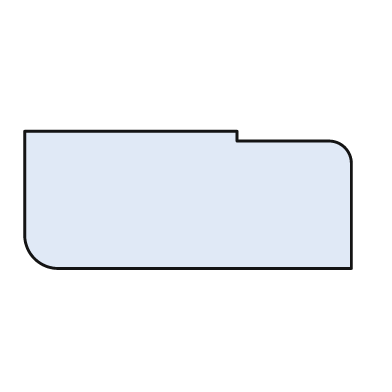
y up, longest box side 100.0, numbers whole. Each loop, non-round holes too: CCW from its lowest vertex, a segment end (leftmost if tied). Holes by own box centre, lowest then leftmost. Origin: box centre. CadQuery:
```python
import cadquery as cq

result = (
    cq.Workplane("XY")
    .moveTo(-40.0, -21.0)
    .lineTo(50.0, -21.0)
    .lineTo(50.0, 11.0)
    .threePointArc((48.0, 16.0), (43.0, 18.0))
    .lineTo(15.0, 18.0)
    .lineTo(15.0, 21.0)
    .lineTo(-50.0, 21.0)
    .lineTo(-50.0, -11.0)
    .threePointArc((-47.0, -18.0), (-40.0, -21.0))
    .close()
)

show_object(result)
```